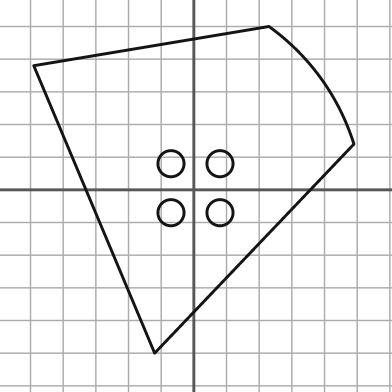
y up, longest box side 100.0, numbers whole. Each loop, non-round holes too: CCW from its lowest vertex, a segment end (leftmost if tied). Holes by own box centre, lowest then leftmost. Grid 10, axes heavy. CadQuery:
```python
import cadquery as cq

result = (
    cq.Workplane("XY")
    .moveTo(-12.0, -50.0)
    .lineTo(49.0, 14.0)
    .threePointArc((39.0, 34.0), (23.0, 50.0))
    .lineTo(-49.0, 38.0)
    .close()
    .moveTo(-7.0, -7.0)
    .circle(4.0)
    .moveTo(8.0, -7.0)
    .circle(4.0)
    .moveTo(-7.0, 8.0)
    .circle(4.0)
    .moveTo(8.0, 8.0)
    .circle(4.0)
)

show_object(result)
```